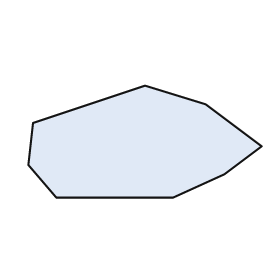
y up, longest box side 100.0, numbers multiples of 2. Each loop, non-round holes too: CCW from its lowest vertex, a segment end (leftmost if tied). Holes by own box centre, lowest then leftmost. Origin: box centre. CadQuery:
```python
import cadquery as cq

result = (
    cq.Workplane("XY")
    .moveTo(-38.0, -24.0)
    .lineTo(12.0, -24.0)
    .lineTo(34.0, -14.0)
    .lineTo(50.0, -2.0)
    .lineTo(26.0, 16.0)
    .lineTo(0.0, 24.0)
    .lineTo(-48.0, 8.0)
    .lineTo(-50.0, -10.0)
    .close()
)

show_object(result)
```